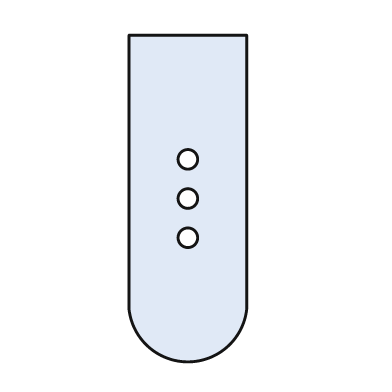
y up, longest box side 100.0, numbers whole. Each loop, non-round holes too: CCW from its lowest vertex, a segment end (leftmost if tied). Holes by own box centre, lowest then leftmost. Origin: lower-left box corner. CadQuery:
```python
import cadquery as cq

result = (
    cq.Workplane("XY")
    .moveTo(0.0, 16.0)
    .threePointArc((18.0, 0.0), (36.0, 16.0))
    .lineTo(36.0, 100.0)
    .lineTo(0.0, 100.0)
    .close()
    .moveTo(18.0, 38.0)
    .circle(3.0)
    .moveTo(18.0, 50.0)
    .circle(3.0)
    .moveTo(18.0, 62.0)
    .circle(3.0)
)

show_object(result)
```